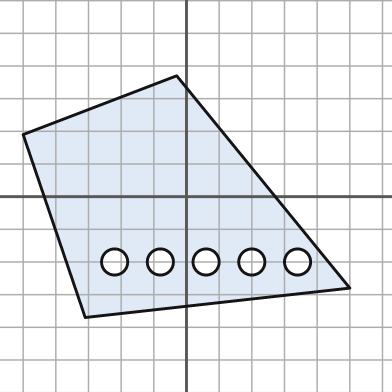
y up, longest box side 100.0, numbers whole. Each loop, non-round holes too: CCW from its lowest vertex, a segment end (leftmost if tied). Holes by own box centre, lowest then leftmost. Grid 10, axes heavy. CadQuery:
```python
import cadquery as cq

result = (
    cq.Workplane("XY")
    .moveTo(-31.0, -37.0)
    .lineTo(50.0, -28.0)
    .lineTo(-3.0, 37.0)
    .lineTo(-50.0, 19.0)
    .close()
    .moveTo(-22.0, -20.0)
    .circle(4.0)
    .moveTo(-8.0, -20.0)
    .circle(4.0)
    .moveTo(6.0, -20.0)
    .circle(4.0)
    .moveTo(20.0, -20.0)
    .circle(4.0)
    .moveTo(34.0, -20.0)
    .circle(4.0)
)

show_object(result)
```